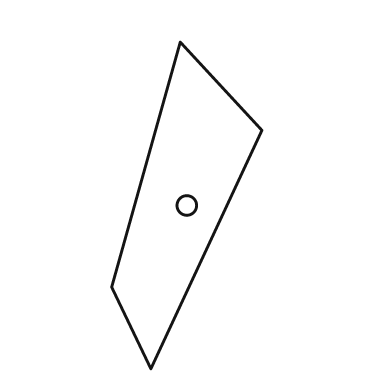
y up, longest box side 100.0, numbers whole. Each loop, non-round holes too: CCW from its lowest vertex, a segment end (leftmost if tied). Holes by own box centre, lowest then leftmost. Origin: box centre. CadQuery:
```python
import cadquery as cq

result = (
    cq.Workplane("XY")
    .moveTo(-11.0, -50.0)
    .lineTo(23.0, 23.0)
    .lineTo(-2.0, 50.0)
    .lineTo(-23.0, -25.0)
    .close()
    .moveTo(0.0, 0.0)
    .circle(3.0)
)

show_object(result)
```